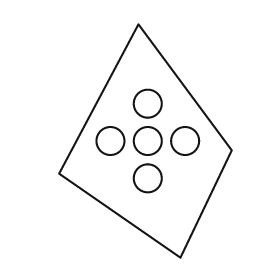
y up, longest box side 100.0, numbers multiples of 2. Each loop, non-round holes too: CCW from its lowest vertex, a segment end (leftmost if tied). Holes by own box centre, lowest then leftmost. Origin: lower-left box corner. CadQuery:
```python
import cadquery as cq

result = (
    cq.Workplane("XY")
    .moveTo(52.0, 0.0)
    .lineTo(74.0, 46.0)
    .lineTo(34.0, 100.0)
    .lineTo(0.0, 36.0)
    .close()
    .moveTo(38.0, 34.0)
    .circle(6.0)
    .moveTo(22.0, 50.0)
    .circle(6.0)
    .moveTo(38.0, 50.0)
    .circle(6.0)
    .moveTo(54.0, 50.0)
    .circle(6.0)
    .moveTo(38.0, 66.0)
    .circle(6.0)
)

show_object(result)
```